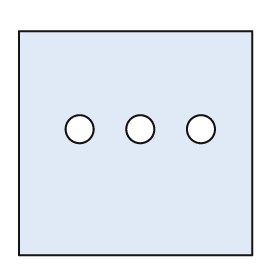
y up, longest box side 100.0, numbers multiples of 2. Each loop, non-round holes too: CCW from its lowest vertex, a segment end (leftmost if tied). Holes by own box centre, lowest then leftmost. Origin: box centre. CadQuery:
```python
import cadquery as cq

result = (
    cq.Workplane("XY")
    .moveTo(-50.0, -48.0)
    .lineTo(50.0, -48.0)
    .lineTo(50.0, 48.0)
    .lineTo(-50.0, 48.0)
    .close()
    .moveTo(-24.0, 6.0)
    .circle(6.0)
    .moveTo(2.0, 6.0)
    .circle(6.0)
    .moveTo(28.0, 6.0)
    .circle(6.0)
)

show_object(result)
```